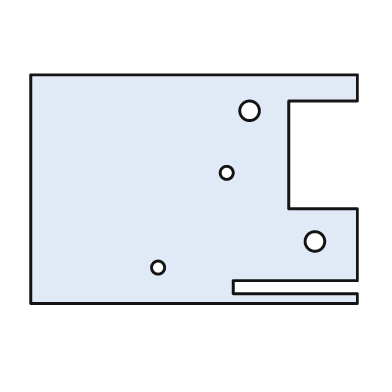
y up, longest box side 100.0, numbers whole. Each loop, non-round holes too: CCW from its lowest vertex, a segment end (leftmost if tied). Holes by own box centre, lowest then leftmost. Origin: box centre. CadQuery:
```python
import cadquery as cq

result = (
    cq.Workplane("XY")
    .moveTo(-50.0, -35.0)
    .lineTo(50.0, -35.0)
    .lineTo(50.0, -32.0)
    .lineTo(12.0, -32.0)
    .lineTo(12.0, -28.0)
    .lineTo(50.0, -28.0)
    .lineTo(50.0, -6.0)
    .lineTo(29.0, -6.0)
    .lineTo(29.0, 27.0)
    .lineTo(50.0, 27.0)
    .lineTo(50.0, 35.0)
    .lineTo(-50.0, 35.0)
    .close()
    .moveTo(-11.0, -24.0)
    .circle(2.0)
    .moveTo(37.0, -16.0)
    .circle(3.0)
    .moveTo(10.0, 5.0)
    .circle(2.0)
    .moveTo(17.0, 24.0)
    .circle(3.0)
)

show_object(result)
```